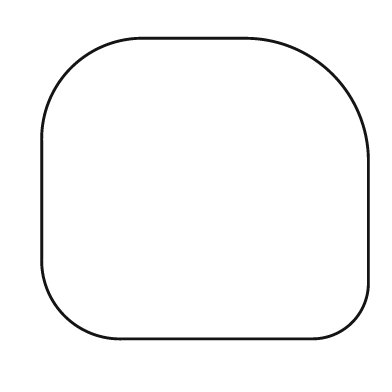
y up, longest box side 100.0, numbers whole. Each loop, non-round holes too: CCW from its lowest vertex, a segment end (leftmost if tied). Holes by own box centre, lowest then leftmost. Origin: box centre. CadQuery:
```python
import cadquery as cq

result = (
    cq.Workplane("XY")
    .moveTo(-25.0, -46.0)
    .lineTo(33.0, -46.0)
    .threePointArc((45.0, -41.0), (50.0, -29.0))
    .lineTo(50.0, 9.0)
    .threePointArc((39.0, 35.0), (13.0, 46.0))
    .lineTo(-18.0, 46.0)
    .threePointArc((-41.0, 37.0), (-50.0, 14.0))
    .lineTo(-50.0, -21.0)
    .threePointArc((-43.0, -39.0), (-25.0, -46.0))
    .close()
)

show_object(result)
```